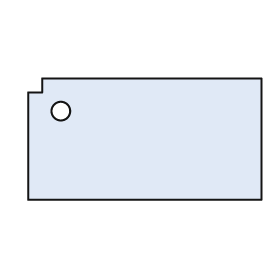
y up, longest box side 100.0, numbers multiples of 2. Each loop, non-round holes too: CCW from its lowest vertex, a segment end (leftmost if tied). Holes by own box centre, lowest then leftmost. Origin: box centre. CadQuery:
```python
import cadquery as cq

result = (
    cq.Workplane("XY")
    .moveTo(-50.0, -26.0)
    .lineTo(50.0, -26.0)
    .lineTo(50.0, 26.0)
    .lineTo(-44.0, 26.0)
    .lineTo(-44.0, 20.0)
    .lineTo(-50.0, 20.0)
    .close()
    .moveTo(-36.0, 12.0)
    .circle(4.0)
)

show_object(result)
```